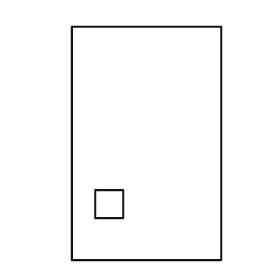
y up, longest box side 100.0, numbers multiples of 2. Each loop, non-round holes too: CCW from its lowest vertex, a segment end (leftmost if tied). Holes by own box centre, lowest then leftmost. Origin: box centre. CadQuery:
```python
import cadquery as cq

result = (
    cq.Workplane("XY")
    .moveTo(-32.0, -50.0)
    .lineTo(32.0, -50.0)
    .lineTo(32.0, 50.0)
    .lineTo(-32.0, 50.0)
    .close()
    .moveTo(-22.0, -32.0)
    .lineTo(-10.0, -32.0)
    .lineTo(-10.0, -20.0)
    .lineTo(-22.0, -20.0)
    .close()
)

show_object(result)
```